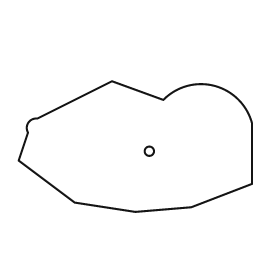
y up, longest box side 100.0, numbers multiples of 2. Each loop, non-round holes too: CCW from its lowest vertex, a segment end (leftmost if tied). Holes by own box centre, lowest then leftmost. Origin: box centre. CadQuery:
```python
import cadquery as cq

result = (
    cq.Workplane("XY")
    .moveTo(0.0, -28.0)
    .lineTo(24.0, -26.0)
    .lineTo(50.0, -16.0)
    .lineTo(50.0, 10.0)
    .threePointArc((34.0, 26.0), (12.0, 20.0))
    .lineTo(-10.0, 28.0)
    .lineTo(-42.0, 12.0)
    .threePointArc((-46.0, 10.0), (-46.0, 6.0))
    .lineTo(-50.0, -6.0)
    .lineTo(-26.0, -24.0)
    .close()
    .moveTo(6.0, -2.0)
    .circle(2.0)
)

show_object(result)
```